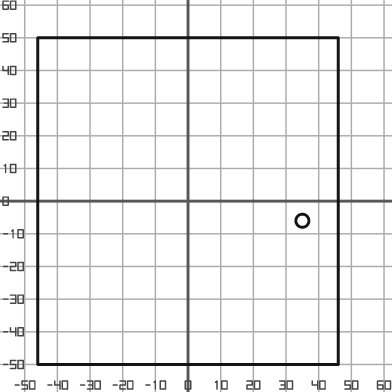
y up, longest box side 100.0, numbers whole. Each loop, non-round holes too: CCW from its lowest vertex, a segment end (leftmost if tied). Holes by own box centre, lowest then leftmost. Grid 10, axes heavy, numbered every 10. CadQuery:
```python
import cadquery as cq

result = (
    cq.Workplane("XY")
    .moveTo(-46.0, -50.0)
    .lineTo(46.0, -50.0)
    .lineTo(46.0, 50.0)
    .lineTo(-46.0, 50.0)
    .close()
    .moveTo(35.0, -6.0)
    .circle(2.0)
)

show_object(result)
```